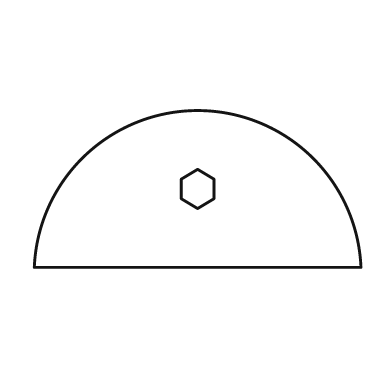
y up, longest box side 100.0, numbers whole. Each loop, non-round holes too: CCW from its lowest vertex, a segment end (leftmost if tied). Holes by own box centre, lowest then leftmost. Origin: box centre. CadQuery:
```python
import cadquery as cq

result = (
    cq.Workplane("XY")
    .moveTo(-50.0, -24.0)
    .lineTo(50.0, -24.0)
    .threePointArc((0.0, 24.0), (-50.0, -24.0))
    .close()
    .moveTo(0.0, -6.0)
    .lineTo(5.0, -3.0)
    .lineTo(5.0, 3.0)
    .lineTo(0.0, 6.0)
    .lineTo(-5.0, 3.0)
    .lineTo(-5.0, -3.0)
    .close()
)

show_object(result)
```